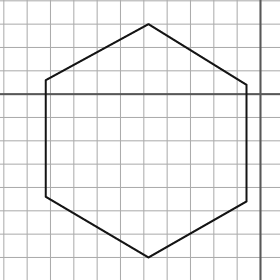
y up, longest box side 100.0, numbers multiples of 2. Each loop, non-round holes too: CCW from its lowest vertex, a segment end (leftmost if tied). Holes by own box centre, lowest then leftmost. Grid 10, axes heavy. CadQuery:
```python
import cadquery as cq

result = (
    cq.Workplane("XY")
    .moveTo(-48.0, -70.0)
    .lineTo(-6.0, -46.0)
    .lineTo(-6.0, 4.0)
    .lineTo(-48.0, 30.0)
    .lineTo(-92.0, 6.0)
    .lineTo(-92.0, -44.0)
    .close()
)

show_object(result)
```